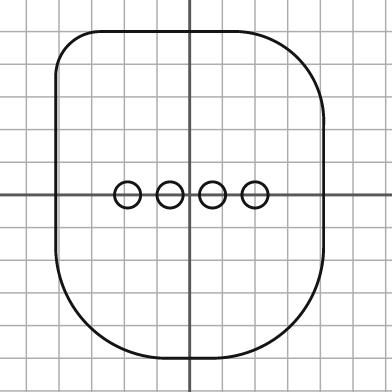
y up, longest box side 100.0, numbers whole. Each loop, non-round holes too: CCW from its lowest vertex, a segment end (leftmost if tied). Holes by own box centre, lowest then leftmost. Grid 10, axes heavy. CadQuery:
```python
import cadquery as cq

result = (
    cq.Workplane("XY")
    .moveTo(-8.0, -50.0)
    .lineTo(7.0, -50.0)
    .threePointArc((31.0, -40.0), (41.0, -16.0))
    .lineTo(41.0, 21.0)
    .threePointArc((33.0, 42.0), (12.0, 50.0))
    .lineTo(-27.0, 50.0)
    .threePointArc((-37.0, 46.0), (-41.0, 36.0))
    .lineTo(-41.0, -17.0)
    .threePointArc((-31.0, -40.0), (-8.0, -50.0))
    .close()
    .moveTo(-19.0, 0.0)
    .circle(4.0)
    .moveTo(-6.0, 0.0)
    .circle(4.0)
    .moveTo(7.0, 0.0)
    .circle(4.0)
    .moveTo(20.0, 0.0)
    .circle(4.0)
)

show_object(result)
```